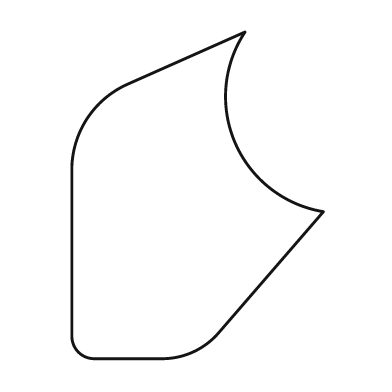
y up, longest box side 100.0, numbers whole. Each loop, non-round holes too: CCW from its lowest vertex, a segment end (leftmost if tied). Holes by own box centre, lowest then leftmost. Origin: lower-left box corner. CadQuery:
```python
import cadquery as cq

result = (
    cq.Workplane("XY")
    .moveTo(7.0, 0.0)
    .lineTo(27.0, 0.0)
    .threePointArc((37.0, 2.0), (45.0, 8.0))
    .lineTo(77.0, 45.0)
    .threePointArc((50.0, 66.0), (53.0, 100.0))
    .lineTo(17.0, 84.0)
    .threePointArc((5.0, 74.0), (0.0, 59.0))
    .lineTo(0.0, 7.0)
    .threePointArc((2.0, 2.0), (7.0, 0.0))
    .close()
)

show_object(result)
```